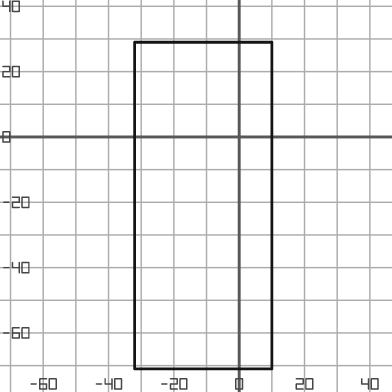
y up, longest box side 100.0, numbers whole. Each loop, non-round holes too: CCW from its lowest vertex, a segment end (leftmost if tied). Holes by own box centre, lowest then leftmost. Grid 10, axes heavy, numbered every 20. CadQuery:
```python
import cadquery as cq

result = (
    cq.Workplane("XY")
    .moveTo(-32.0, -71.0)
    .lineTo(10.0, -71.0)
    .lineTo(10.0, 29.0)
    .lineTo(-32.0, 29.0)
    .close()
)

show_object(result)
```